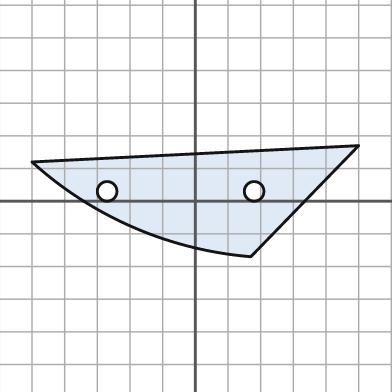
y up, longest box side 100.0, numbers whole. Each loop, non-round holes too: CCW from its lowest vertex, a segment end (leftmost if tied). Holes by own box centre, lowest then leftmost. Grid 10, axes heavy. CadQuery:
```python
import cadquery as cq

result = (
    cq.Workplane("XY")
    .moveTo(17.0, -17.0)
    .lineTo(50.0, 17.0)
    .lineTo(-50.0, 12.0)
    .threePointArc((-19.0, -8.0), (17.0, -17.0))
    .close()
    .moveTo(-27.0, 3.0)
    .circle(3.0)
    .moveTo(18.0, 3.0)
    .circle(3.0)
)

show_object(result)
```